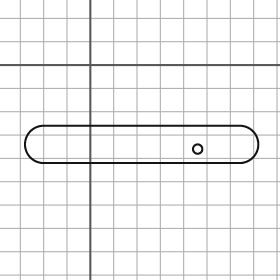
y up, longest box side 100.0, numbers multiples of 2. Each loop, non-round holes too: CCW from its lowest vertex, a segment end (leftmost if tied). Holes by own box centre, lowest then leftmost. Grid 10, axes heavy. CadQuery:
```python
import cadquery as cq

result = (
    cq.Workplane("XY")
    .moveTo(-20.0, -42.0)
    .lineTo(64.0, -42.0)
    .threePointArc((72.0, -34.0), (64.0, -26.0))
    .lineTo(-20.0, -26.0)
    .threePointArc((-28.0, -34.0), (-20.0, -42.0))
    .close()
    .moveTo(46.0, -36.0)
    .circle(2.0)
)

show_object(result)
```